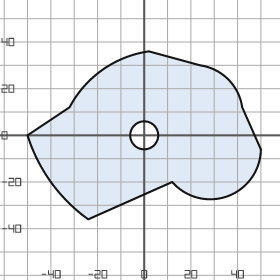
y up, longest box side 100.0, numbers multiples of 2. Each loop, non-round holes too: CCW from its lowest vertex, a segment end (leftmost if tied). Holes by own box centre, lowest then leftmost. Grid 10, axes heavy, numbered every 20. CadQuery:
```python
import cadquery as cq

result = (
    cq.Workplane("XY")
    .moveTo(-24.0, -36.0)
    .lineTo(12.0, -20.0)
    .threePointArc((36.0, -26.0), (50.0, -6.0))
    .lineTo(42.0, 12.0)
    .threePointArc((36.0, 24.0), (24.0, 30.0))
    .lineTo(2.0, 36.0)
    .threePointArc((-18.0, 28.0), (-32.0, 12.0))
    .lineTo(-50.0, 0.0)
    .threePointArc((-40.0, -20.0), (-24.0, -36.0))
    .close()
    .moveTo(0.0, 0.0)
    .circle(6.0)
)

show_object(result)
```